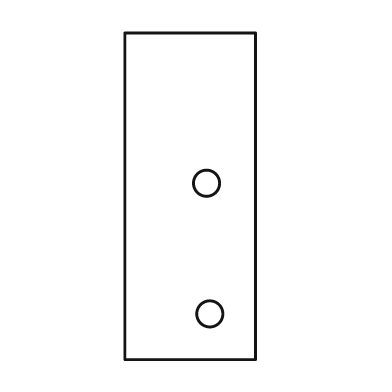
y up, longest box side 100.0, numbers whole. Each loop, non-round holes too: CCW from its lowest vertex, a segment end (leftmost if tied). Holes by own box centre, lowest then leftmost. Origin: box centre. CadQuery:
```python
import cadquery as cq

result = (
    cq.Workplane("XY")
    .moveTo(-20.0, -50.0)
    .lineTo(20.0, -50.0)
    .lineTo(20.0, 50.0)
    .lineTo(-20.0, 50.0)
    .close()
    .moveTo(6.0, -36.0)
    .circle(4.0)
    .moveTo(5.0, 4.0)
    .circle(4.0)
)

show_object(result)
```